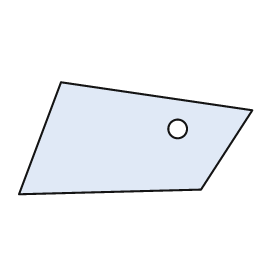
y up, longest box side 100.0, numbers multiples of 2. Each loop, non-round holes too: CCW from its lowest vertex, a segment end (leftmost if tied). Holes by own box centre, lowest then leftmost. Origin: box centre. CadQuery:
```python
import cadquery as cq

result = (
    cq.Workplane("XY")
    .moveTo(-50.0, -24.0)
    .lineTo(28.0, -22.0)
    .lineTo(50.0, 12.0)
    .lineTo(-32.0, 24.0)
    .close()
    .moveTo(18.0, 4.0)
    .circle(4.0)
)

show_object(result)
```